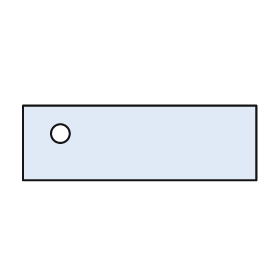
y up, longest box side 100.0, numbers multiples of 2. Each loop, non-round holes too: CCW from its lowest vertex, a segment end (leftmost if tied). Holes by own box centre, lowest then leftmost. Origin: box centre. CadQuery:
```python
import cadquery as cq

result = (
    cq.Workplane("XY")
    .moveTo(-50.0, -16.0)
    .lineTo(50.0, -16.0)
    .lineTo(50.0, 16.0)
    .lineTo(-50.0, 16.0)
    .close()
    .moveTo(-34.0, 4.0)
    .circle(4.0)
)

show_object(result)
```